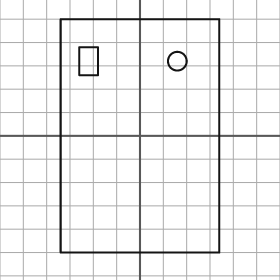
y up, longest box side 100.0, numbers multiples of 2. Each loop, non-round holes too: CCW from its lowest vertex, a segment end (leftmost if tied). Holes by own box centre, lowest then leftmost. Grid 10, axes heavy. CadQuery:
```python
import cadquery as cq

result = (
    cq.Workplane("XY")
    .moveTo(-34.0, -50.0)
    .lineTo(34.0, -50.0)
    .lineTo(34.0, 50.0)
    .lineTo(-34.0, 50.0)
    .close()
    .moveTo(-26.0, 26.0)
    .lineTo(-18.0, 26.0)
    .lineTo(-18.0, 38.0)
    .lineTo(-26.0, 38.0)
    .close()
    .moveTo(16.0, 32.0)
    .circle(4.0)
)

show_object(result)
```